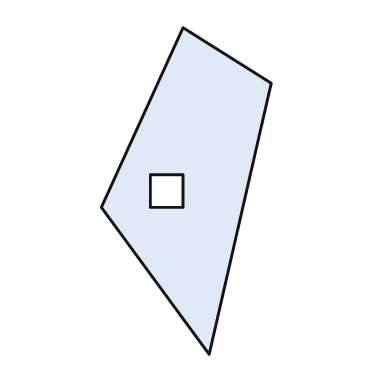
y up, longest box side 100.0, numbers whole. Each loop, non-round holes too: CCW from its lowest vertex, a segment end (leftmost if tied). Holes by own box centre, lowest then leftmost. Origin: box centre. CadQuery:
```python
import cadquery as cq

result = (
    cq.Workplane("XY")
    .moveTo(7.0, -50.0)
    .lineTo(26.0, 33.0)
    .lineTo(-1.0, 50.0)
    .lineTo(-26.0, -5.0)
    .close()
    .moveTo(-11.0, -5.0)
    .lineTo(-1.0, -5.0)
    .lineTo(-1.0, 5.0)
    .lineTo(-11.0, 5.0)
    .close()
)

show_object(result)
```